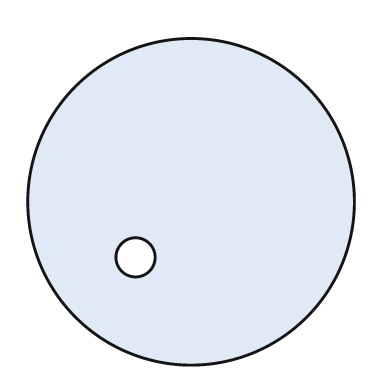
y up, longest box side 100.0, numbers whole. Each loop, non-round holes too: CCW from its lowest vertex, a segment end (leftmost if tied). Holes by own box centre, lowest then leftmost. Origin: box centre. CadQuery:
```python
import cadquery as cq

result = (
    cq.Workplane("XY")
    .moveTo(0.0, 0.0)
    .circle(50.0)
    .moveTo(-17.0, -17.0)
    .circle(6.0)
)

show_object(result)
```